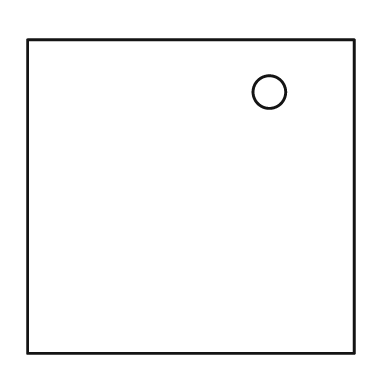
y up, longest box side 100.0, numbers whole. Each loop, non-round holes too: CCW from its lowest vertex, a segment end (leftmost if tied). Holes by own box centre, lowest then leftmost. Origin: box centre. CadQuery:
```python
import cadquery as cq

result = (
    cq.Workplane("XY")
    .moveTo(-50.0, -48.0)
    .lineTo(50.0, -48.0)
    .lineTo(50.0, 48.0)
    .lineTo(-50.0, 48.0)
    .close()
    .moveTo(24.0, 32.0)
    .circle(5.0)
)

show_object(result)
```